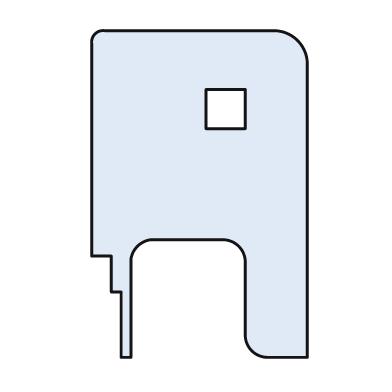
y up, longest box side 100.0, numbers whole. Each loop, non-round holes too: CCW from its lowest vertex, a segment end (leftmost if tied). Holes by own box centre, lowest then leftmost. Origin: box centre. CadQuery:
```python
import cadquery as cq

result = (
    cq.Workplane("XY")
    .moveTo(-24.0, -50.0)
    .lineTo(-21.0, -50.0)
    .lineTo(-21.0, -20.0)
    .threePointArc((-19.0, -16.0), (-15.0, -14.0))
    .lineTo(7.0, -14.0)
    .threePointArc((12.0, -16.0), (14.0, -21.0))
    .lineTo(14.0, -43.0)
    .threePointArc((16.0, -48.0), (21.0, -50.0))
    .lineTo(33.0, -50.0)
    .lineTo(33.0, 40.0)
    .threePointArc((30.0, 47.0), (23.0, 50.0))
    .lineTo(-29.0, 50.0)
    .threePointArc((-32.0, 49.0), (-33.0, 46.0))
    .lineTo(-33.0, -19.0)
    .lineTo(-27.0, -19.0)
    .lineTo(-27.0, -30.0)
    .lineTo(-24.0, -30.0)
    .close()
    .moveTo(2.0, 20.0)
    .lineTo(14.0, 20.0)
    .lineTo(14.0, 32.0)
    .lineTo(2.0, 32.0)
    .close()
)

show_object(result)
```